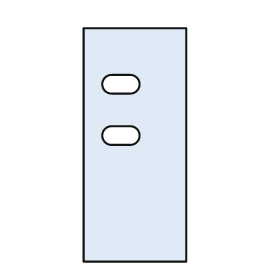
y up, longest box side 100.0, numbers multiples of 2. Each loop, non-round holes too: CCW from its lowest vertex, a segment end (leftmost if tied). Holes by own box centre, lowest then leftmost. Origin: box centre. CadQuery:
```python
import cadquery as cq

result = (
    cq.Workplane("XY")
    .moveTo(-22.0, -50.0)
    .lineTo(22.0, -50.0)
    .lineTo(22.0, 50.0)
    .lineTo(-22.0, 50.0)
    .close()
    .moveTo(-10.0, 0.0)
    .lineTo(-2.0, 0.0)
    .threePointArc((2.0, 4.0), (-2.0, 8.0))
    .lineTo(-10.0, 8.0)
    .threePointArc((-14.0, 4.0), (-10.0, 0.0))
    .close()
    .moveTo(-10.0, 22.0)
    .lineTo(-2.0, 22.0)
    .threePointArc((2.0, 26.0), (-2.0, 30.0))
    .lineTo(-10.0, 30.0)
    .threePointArc((-14.0, 26.0), (-10.0, 22.0))
    .close()
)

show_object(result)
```